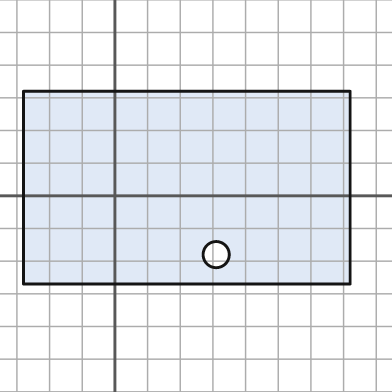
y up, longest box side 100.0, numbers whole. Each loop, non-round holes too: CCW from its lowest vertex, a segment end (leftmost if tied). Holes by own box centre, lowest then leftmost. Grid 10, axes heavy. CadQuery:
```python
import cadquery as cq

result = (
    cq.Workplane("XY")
    .moveTo(-28.0, -27.0)
    .lineTo(72.0, -27.0)
    .lineTo(72.0, 32.0)
    .lineTo(-28.0, 32.0)
    .close()
    .moveTo(31.0, -18.0)
    .circle(4.0)
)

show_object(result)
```